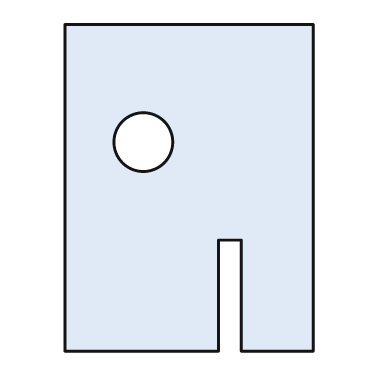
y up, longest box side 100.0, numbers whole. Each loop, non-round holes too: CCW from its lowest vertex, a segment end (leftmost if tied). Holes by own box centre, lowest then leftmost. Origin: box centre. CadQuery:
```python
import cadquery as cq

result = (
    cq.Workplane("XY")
    .moveTo(-38.0, -50.0)
    .lineTo(9.0, -50.0)
    .lineTo(9.0, -16.0)
    .lineTo(16.0, -16.0)
    .lineTo(16.0, -50.0)
    .lineTo(38.0, -50.0)
    .lineTo(38.0, 50.0)
    .lineTo(-38.0, 50.0)
    .close()
    .moveTo(-14.0, 14.0)
    .circle(9.0)
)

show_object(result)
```